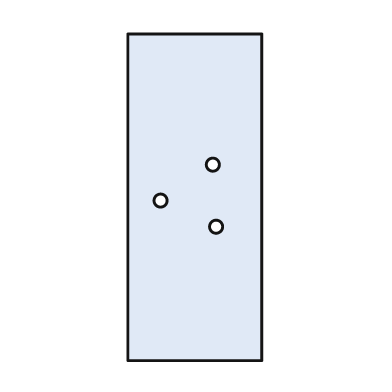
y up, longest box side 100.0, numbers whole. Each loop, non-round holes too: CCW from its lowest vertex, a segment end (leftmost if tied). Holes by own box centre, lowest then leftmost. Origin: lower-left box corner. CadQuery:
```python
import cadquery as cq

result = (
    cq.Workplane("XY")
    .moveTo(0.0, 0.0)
    .lineTo(41.0, 0.0)
    .lineTo(41.0, 100.0)
    .lineTo(0.0, 100.0)
    .close()
    .moveTo(27.0, 41.0)
    .circle(2.0)
    .moveTo(10.0, 49.0)
    .circle(2.0)
    .moveTo(26.0, 60.0)
    .circle(2.0)
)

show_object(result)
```